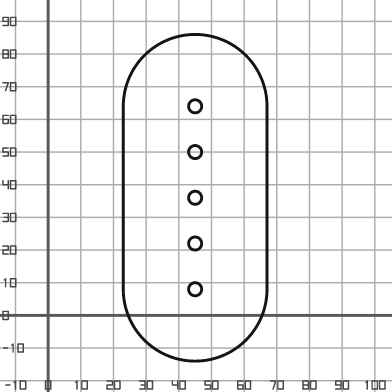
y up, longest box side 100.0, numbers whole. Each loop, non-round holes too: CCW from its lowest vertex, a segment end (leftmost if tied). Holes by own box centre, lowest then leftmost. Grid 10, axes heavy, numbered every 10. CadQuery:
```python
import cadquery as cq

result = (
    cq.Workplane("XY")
    .moveTo(23.0, 8.0)
    .threePointArc((45.0, -14.0), (67.0, 8.0))
    .lineTo(67.0, 64.0)
    .threePointArc((45.0, 86.0), (23.0, 64.0))
    .close()
    .moveTo(45.0, 8.0)
    .circle(2.0)
    .moveTo(45.0, 22.0)
    .circle(2.0)
    .moveTo(45.0, 36.0)
    .circle(2.0)
    .moveTo(45.0, 50.0)
    .circle(2.0)
    .moveTo(45.0, 64.0)
    .circle(2.0)
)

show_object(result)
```